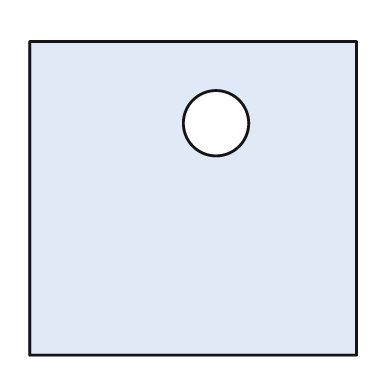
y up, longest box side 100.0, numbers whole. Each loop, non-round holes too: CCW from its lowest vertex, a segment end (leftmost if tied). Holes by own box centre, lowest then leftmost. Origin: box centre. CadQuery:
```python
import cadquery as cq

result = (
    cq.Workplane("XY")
    .moveTo(-50.0, -48.0)
    .lineTo(50.0, -48.0)
    .lineTo(50.0, 48.0)
    .lineTo(-50.0, 48.0)
    .close()
    .moveTo(7.0, 23.0)
    .circle(10.0)
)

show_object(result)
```